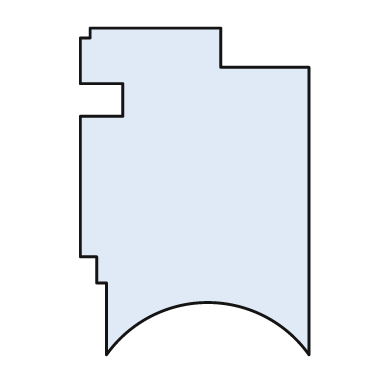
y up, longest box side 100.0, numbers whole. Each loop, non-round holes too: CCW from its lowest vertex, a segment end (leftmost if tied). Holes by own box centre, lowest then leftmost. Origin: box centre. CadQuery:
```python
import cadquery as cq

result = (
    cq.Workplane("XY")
    .moveTo(-27.0, -50.0)
    .threePointArc((4.0, -34.0), (35.0, -50.0))
    .lineTo(35.0, 38.0)
    .lineTo(8.0, 38.0)
    .lineTo(8.0, 50.0)
    .lineTo(-32.0, 50.0)
    .lineTo(-32.0, 47.0)
    .lineTo(-35.0, 47.0)
    .lineTo(-35.0, 33.0)
    .lineTo(-22.0, 33.0)
    .lineTo(-22.0, 23.0)
    .lineTo(-35.0, 23.0)
    .lineTo(-35.0, -20.0)
    .lineTo(-30.0, -20.0)
    .lineTo(-30.0, -28.0)
    .lineTo(-27.0, -28.0)
    .close()
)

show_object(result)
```